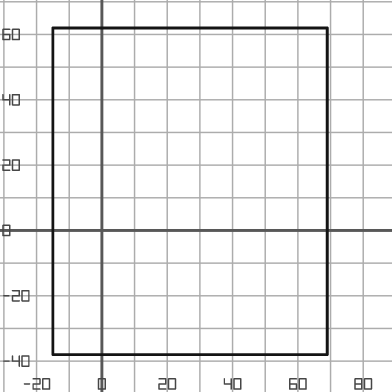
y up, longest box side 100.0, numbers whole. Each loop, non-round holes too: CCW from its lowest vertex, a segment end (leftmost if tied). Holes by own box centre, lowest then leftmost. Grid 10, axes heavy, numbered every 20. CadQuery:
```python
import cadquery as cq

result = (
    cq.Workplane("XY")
    .moveTo(-15.0, -38.0)
    .lineTo(69.0, -38.0)
    .lineTo(69.0, 62.0)
    .lineTo(-15.0, 62.0)
    .close()
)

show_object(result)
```